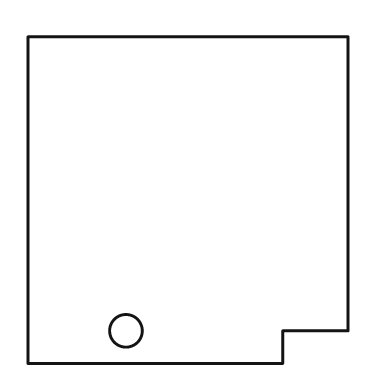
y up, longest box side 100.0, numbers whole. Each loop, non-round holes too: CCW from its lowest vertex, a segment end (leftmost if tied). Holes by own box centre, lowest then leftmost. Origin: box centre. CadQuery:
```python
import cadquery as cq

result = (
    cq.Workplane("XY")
    .moveTo(-49.0, -50.0)
    .lineTo(29.0, -50.0)
    .lineTo(29.0, -40.0)
    .lineTo(49.0, -40.0)
    .lineTo(49.0, 50.0)
    .lineTo(-49.0, 50.0)
    .close()
    .moveTo(-19.0, -40.0)
    .circle(5.0)
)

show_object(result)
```